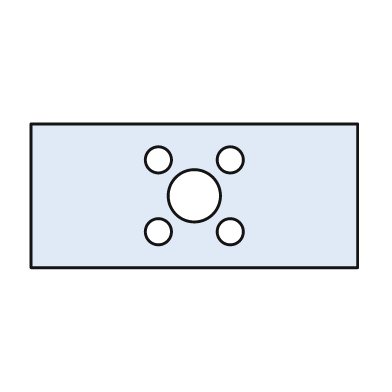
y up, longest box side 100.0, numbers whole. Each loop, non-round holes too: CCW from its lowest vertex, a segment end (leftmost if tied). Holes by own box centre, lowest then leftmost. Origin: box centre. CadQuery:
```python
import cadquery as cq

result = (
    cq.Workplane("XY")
    .moveTo(-50.0, -22.0)
    .lineTo(50.0, -22.0)
    .lineTo(50.0, 22.0)
    .lineTo(-50.0, 22.0)
    .close()
    .moveTo(-11.0, -11.0)
    .circle(4.0)
    .moveTo(11.0, -11.0)
    .circle(4.0)
    .moveTo(0.0, 0.0)
    .circle(8.0)
    .moveTo(-11.0, 11.0)
    .circle(4.0)
    .moveTo(11.0, 11.0)
    .circle(4.0)
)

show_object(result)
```